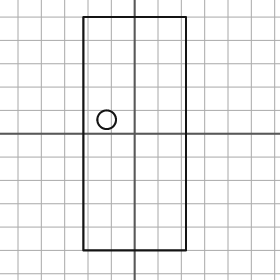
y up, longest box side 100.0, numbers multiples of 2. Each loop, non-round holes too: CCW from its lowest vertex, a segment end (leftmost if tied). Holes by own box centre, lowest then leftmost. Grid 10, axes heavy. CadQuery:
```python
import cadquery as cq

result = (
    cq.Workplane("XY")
    .moveTo(-22.0, -50.0)
    .lineTo(22.0, -50.0)
    .lineTo(22.0, 50.0)
    .lineTo(-22.0, 50.0)
    .close()
    .moveTo(-12.0, 6.0)
    .circle(4.0)
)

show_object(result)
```